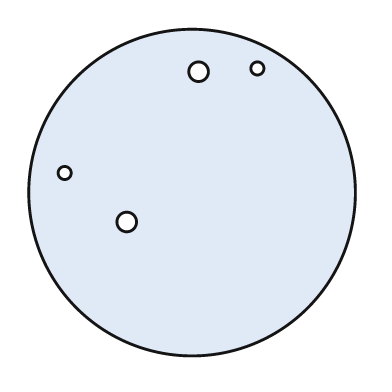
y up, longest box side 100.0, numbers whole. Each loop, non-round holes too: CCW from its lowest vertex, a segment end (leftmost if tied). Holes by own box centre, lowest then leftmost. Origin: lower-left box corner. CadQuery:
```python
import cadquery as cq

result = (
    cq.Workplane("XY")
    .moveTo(50.0, 50.0)
    .circle(50.0)
    .moveTo(30.0, 41.0)
    .circle(3.0)
    .moveTo(11.0, 56.0)
    .circle(2.0)
    .moveTo(52.0, 87.0)
    .circle(3.0)
    .moveTo(70.0, 88.0)
    .circle(2.0)
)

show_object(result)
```